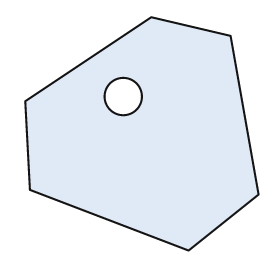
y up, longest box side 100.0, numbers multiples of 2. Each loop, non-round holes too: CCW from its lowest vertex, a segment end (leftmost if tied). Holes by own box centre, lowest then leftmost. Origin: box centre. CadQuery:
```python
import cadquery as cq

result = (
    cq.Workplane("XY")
    .moveTo(20.0, -50.0)
    .lineTo(50.0, -26.0)
    .lineTo(38.0, 42.0)
    .lineTo(4.0, 50.0)
    .lineTo(-50.0, 14.0)
    .lineTo(-48.0, -24.0)
    .close()
    .moveTo(-8.0, 16.0)
    .circle(8.0)
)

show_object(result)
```